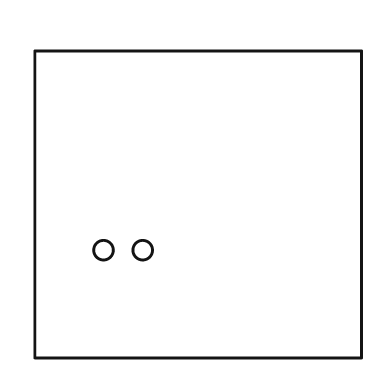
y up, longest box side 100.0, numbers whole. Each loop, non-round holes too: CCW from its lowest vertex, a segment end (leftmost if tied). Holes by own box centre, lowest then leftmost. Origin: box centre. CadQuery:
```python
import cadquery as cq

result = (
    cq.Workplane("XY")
    .moveTo(-50.0, -47.0)
    .lineTo(50.0, -47.0)
    .lineTo(50.0, 47.0)
    .lineTo(-50.0, 47.0)
    .close()
    .moveTo(-29.0, -14.0)
    .circle(3.0)
    .moveTo(-17.0, -14.0)
    .circle(3.0)
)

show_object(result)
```